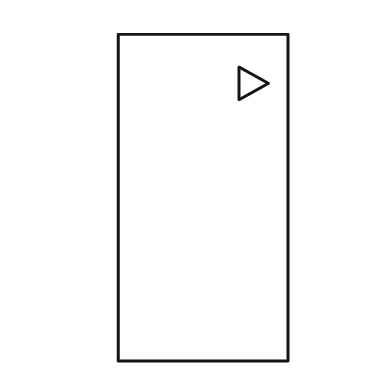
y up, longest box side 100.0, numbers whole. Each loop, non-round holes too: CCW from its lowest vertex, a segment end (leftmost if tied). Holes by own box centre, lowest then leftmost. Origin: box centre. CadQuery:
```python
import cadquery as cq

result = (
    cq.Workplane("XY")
    .moveTo(-26.0, -50.0)
    .lineTo(26.0, -50.0)
    .lineTo(26.0, 50.0)
    .lineTo(-26.0, 50.0)
    .close()
    .moveTo(11.0, 30.0)
    .lineTo(20.0, 35.0)
    .lineTo(11.0, 40.0)
    .close()
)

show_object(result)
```